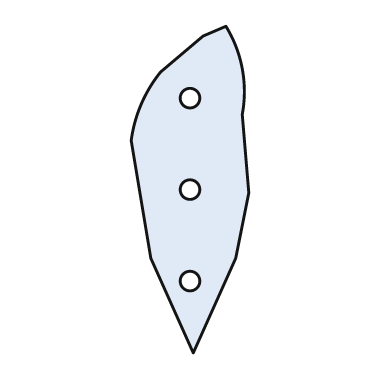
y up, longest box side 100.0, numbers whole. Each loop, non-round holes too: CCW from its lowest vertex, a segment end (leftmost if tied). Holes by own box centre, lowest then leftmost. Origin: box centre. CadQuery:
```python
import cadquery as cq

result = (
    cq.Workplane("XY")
    .moveTo(1.0, -50.0)
    .lineTo(14.0, -21.0)
    .lineTo(18.0, -1.0)
    .lineTo(16.0, 23.0)
    .threePointArc((16.0, 37.0), (11.0, 50.0))
    .lineTo(4.0, 47.0)
    .lineTo(-9.0, 36.0)
    .threePointArc((-15.0, 26.0), (-18.0, 15.0))
    .lineTo(-12.0, -21.0)
    .close()
    .moveTo(0.0, -28.0)
    .circle(3.0)
    .moveTo(0.0, 0.0)
    .circle(3.0)
    .moveTo(0.0, 28.0)
    .circle(3.0)
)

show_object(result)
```